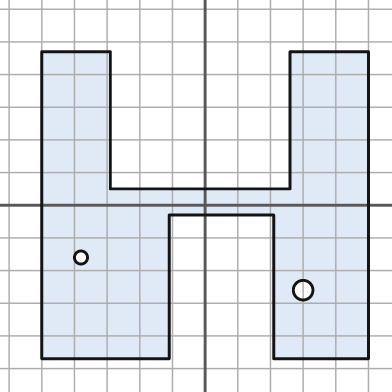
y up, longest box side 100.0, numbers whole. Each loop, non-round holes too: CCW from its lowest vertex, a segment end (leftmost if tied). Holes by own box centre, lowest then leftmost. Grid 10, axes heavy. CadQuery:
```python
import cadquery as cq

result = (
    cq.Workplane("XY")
    .moveTo(-50.0, -47.0)
    .lineTo(-11.0, -47.0)
    .lineTo(-11.0, -3.0)
    .lineTo(21.0, -3.0)
    .lineTo(21.0, -47.0)
    .lineTo(50.0, -47.0)
    .lineTo(50.0, 47.0)
    .lineTo(26.0, 47.0)
    .lineTo(26.0, 5.0)
    .lineTo(-29.0, 5.0)
    .lineTo(-29.0, 47.0)
    .lineTo(-50.0, 47.0)
    .close()
    .moveTo(30.0, -26.0)
    .circle(3.0)
    .moveTo(-38.0, -16.0)
    .circle(2.0)
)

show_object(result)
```